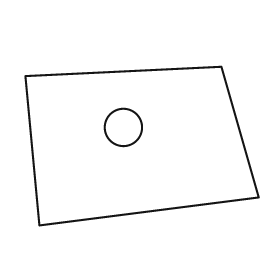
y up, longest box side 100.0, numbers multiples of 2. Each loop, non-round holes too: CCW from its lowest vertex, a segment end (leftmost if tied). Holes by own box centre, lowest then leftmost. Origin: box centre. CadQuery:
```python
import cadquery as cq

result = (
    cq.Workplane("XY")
    .moveTo(-44.0, -34.0)
    .lineTo(50.0, -22.0)
    .lineTo(34.0, 34.0)
    .lineTo(-50.0, 30.0)
    .close()
    .moveTo(-8.0, 8.0)
    .circle(8.0)
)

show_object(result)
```